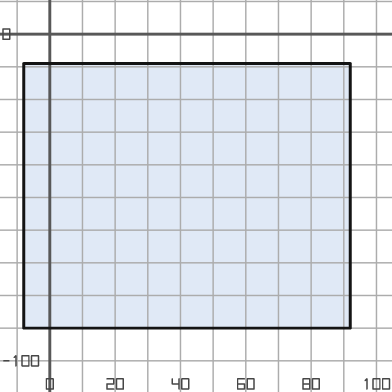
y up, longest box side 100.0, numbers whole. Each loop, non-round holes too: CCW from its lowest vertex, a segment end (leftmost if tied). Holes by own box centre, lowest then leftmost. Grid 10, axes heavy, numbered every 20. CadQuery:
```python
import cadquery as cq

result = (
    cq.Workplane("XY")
    .moveTo(-8.0, -90.0)
    .lineTo(92.0, -90.0)
    .lineTo(92.0, -9.0)
    .lineTo(-8.0, -9.0)
    .close()
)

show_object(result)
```